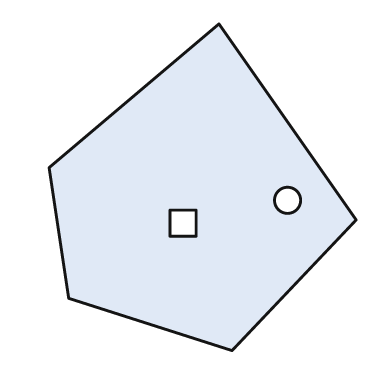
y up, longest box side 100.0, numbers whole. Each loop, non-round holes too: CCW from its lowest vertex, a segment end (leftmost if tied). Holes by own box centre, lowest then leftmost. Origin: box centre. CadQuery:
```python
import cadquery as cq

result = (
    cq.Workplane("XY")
    .moveTo(9.0, -50.0)
    .lineTo(47.0, -10.0)
    .lineTo(5.0, 50.0)
    .lineTo(-47.0, 6.0)
    .lineTo(-41.0, -34.0)
    .close()
    .moveTo(-10.0, -15.0)
    .lineTo(-2.0, -15.0)
    .lineTo(-2.0, -7.0)
    .lineTo(-10.0, -7.0)
    .close()
    .moveTo(26.0, -4.0)
    .circle(4.0)
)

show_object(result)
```